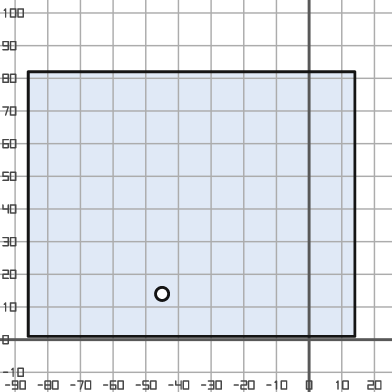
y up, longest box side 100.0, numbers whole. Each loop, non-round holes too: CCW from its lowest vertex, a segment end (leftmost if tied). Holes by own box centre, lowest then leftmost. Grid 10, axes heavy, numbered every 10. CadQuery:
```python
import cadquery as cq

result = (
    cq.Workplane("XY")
    .moveTo(-86.0, 1.0)
    .lineTo(14.0, 1.0)
    .lineTo(14.0, 82.0)
    .lineTo(-86.0, 82.0)
    .close()
    .moveTo(-45.0, 14.0)
    .circle(2.0)
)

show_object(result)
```